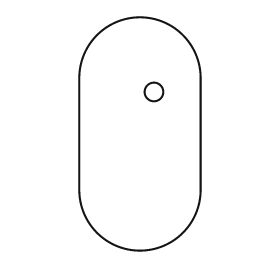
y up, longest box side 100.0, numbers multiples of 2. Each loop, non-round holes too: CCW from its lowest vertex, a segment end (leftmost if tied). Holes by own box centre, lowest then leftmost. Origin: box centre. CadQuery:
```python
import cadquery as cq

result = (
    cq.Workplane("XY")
    .moveTo(-26.0, -24.0)
    .threePointArc((0.0, -50.0), (26.0, -24.0))
    .lineTo(26.0, 24.0)
    .threePointArc((0.0, 50.0), (-26.0, 24.0))
    .close()
    .moveTo(6.0, 18.0)
    .circle(4.0)
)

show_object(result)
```